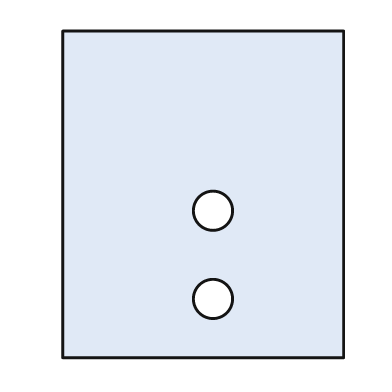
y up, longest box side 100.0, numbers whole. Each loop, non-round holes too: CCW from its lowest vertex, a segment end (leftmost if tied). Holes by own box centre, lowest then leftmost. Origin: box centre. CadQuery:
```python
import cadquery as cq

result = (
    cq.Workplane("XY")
    .moveTo(-43.0, -50.0)
    .lineTo(43.0, -50.0)
    .lineTo(43.0, 50.0)
    .lineTo(-43.0, 50.0)
    .close()
    .moveTo(3.0, -32.0)
    .circle(6.0)
    .moveTo(3.0, -5.0)
    .circle(6.0)
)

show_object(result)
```